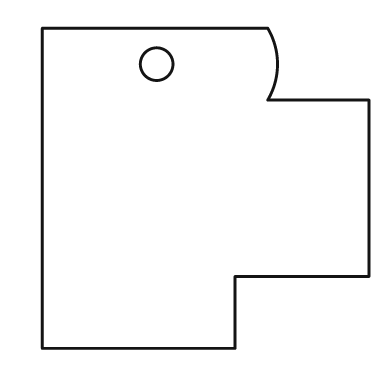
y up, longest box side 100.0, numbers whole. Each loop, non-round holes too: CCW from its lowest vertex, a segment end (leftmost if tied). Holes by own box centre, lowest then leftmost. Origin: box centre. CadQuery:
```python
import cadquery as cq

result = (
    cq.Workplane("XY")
    .moveTo(-50.0, -49.0)
    .lineTo(9.0, -49.0)
    .lineTo(9.0, -27.0)
    .lineTo(50.0, -27.0)
    .lineTo(50.0, 27.0)
    .lineTo(19.0, 27.0)
    .threePointArc((22.0, 38.0), (19.0, 49.0))
    .lineTo(-50.0, 49.0)
    .close()
    .moveTo(-15.0, 38.0)
    .circle(5.0)
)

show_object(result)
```